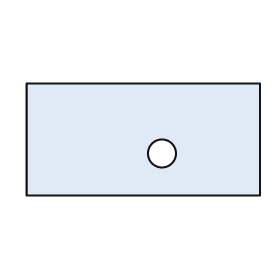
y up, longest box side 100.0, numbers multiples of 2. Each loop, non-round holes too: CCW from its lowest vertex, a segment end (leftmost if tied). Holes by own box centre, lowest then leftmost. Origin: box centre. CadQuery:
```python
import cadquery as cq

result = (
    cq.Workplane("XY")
    .moveTo(-50.0, -24.0)
    .lineTo(50.0, -24.0)
    .lineTo(50.0, 24.0)
    .lineTo(-50.0, 24.0)
    .close()
    .moveTo(8.0, -6.0)
    .circle(6.0)
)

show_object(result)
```